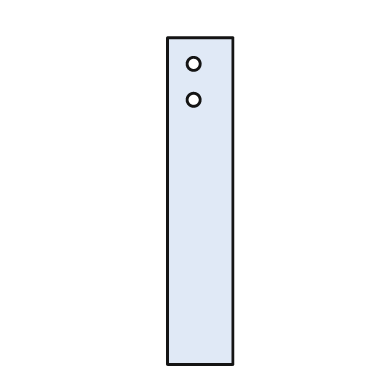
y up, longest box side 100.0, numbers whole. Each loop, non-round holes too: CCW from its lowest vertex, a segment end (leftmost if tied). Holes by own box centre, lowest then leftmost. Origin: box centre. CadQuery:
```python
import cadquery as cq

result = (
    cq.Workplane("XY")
    .moveTo(-10.0, -50.0)
    .lineTo(10.0, -50.0)
    .lineTo(10.0, 50.0)
    .lineTo(-10.0, 50.0)
    .close()
    .moveTo(-2.0, 31.0)
    .circle(2.0)
    .moveTo(-2.0, 42.0)
    .circle(2.0)
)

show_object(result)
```